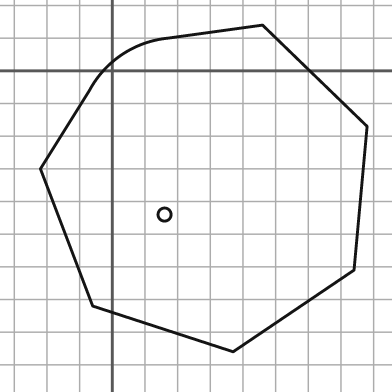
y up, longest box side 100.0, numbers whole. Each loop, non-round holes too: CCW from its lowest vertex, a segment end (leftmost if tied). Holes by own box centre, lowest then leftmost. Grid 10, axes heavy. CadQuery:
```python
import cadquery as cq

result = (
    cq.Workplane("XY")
    .moveTo(37.0, -86.0)
    .lineTo(74.0, -61.0)
    .lineTo(78.0, -17.0)
    .lineTo(46.0, 14.0)
    .lineTo(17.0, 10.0)
    .threePointArc((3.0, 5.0), (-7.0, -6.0))
    .lineTo(-22.0, -30.0)
    .lineTo(-6.0, -72.0)
    .close()
    .moveTo(16.0, -44.0)
    .circle(2.0)
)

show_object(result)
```